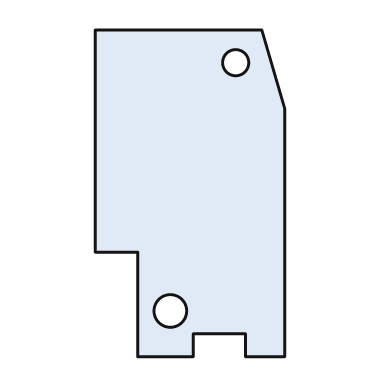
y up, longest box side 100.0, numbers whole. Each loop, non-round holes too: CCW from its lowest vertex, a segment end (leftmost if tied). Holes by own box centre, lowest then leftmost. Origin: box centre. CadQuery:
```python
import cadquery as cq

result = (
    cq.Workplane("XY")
    .moveTo(-16.0, -50.0)
    .lineTo(1.0, -50.0)
    .lineTo(1.0, -43.0)
    .lineTo(17.0, -43.0)
    .lineTo(17.0, -50.0)
    .lineTo(29.0, -50.0)
    .lineTo(29.0, 26.0)
    .lineTo(22.0, 50.0)
    .lineTo(-29.0, 50.0)
    .lineTo(-29.0, -18.0)
    .lineTo(-16.0, -18.0)
    .close()
    .moveTo(-6.0, -36.0)
    .circle(5.0)
    .moveTo(14.0, 40.0)
    .circle(4.0)
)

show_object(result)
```